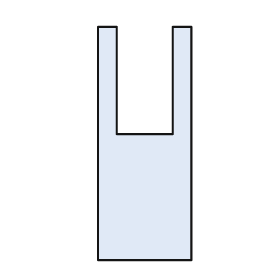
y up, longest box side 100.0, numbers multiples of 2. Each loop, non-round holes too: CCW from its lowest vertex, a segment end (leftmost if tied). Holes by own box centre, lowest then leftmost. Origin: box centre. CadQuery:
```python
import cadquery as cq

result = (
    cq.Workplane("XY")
    .moveTo(-20.0, -50.0)
    .lineTo(20.0, -50.0)
    .lineTo(20.0, 50.0)
    .lineTo(12.0, 50.0)
    .lineTo(12.0, 4.0)
    .lineTo(-12.0, 4.0)
    .lineTo(-12.0, 50.0)
    .lineTo(-20.0, 50.0)
    .close()
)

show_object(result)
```